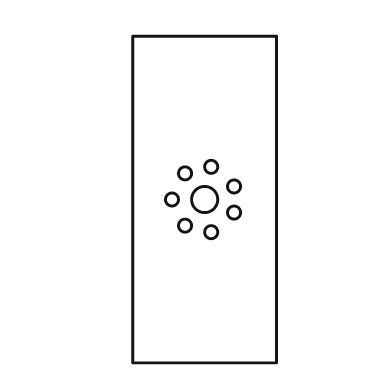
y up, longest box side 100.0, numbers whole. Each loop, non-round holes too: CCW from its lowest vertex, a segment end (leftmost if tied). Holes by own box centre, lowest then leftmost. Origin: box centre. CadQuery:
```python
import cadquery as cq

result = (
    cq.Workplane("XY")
    .moveTo(-22.0, -50.0)
    .lineTo(22.0, -50.0)
    .lineTo(22.0, 50.0)
    .lineTo(-22.0, 50.0)
    .close()
    .moveTo(2.0, -10.0)
    .circle(2.0)
    .moveTo(-6.0, -8.0)
    .circle(2.0)
    .moveTo(9.0, -4.0)
    .circle(2.0)
    .moveTo(-10.0, 0.0)
    .circle(2.0)
    .moveTo(0.0, 0.0)
    .circle(4.0)
    .moveTo(9.0, 4.0)
    .circle(2.0)
    .moveTo(-6.0, 8.0)
    .circle(2.0)
    .moveTo(2.0, 10.0)
    .circle(2.0)
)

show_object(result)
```